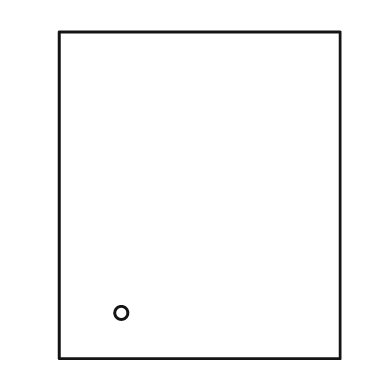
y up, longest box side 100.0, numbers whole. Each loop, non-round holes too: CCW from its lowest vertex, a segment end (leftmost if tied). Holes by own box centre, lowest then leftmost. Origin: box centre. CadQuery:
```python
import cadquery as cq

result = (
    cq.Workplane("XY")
    .moveTo(-43.0, -50.0)
    .lineTo(43.0, -50.0)
    .lineTo(43.0, 50.0)
    .lineTo(-43.0, 50.0)
    .close()
    .moveTo(-24.0, -36.0)
    .circle(2.0)
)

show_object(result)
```